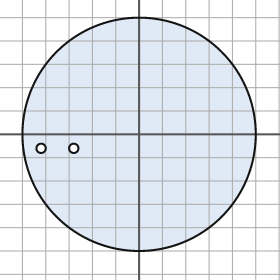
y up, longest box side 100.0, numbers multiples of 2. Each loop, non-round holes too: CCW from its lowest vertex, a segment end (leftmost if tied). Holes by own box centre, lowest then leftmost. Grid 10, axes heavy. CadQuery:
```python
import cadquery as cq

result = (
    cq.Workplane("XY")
    .moveTo(0.0, 0.0)
    .circle(50.0)
    .moveTo(-42.0, -6.0)
    .circle(2.0)
    .moveTo(-28.0, -6.0)
    .circle(2.0)
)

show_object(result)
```